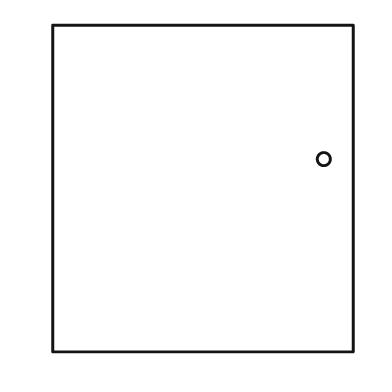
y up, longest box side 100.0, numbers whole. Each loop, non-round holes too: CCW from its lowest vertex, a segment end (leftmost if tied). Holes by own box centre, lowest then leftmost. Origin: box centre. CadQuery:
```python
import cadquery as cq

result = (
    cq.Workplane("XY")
    .moveTo(-46.0, -50.0)
    .lineTo(46.0, -50.0)
    .lineTo(46.0, 50.0)
    .lineTo(-46.0, 50.0)
    .close()
    .moveTo(37.0, 9.0)
    .circle(2.0)
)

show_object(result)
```